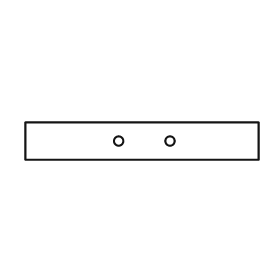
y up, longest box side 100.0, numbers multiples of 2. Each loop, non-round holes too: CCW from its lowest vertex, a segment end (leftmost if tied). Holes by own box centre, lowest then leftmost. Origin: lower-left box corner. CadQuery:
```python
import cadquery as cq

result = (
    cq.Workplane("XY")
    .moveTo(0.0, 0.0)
    .lineTo(100.0, 0.0)
    .lineTo(100.0, 16.0)
    .lineTo(0.0, 16.0)
    .close()
    .moveTo(40.0, 8.0)
    .circle(2.0)
    .moveTo(62.0, 8.0)
    .circle(2.0)
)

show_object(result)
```